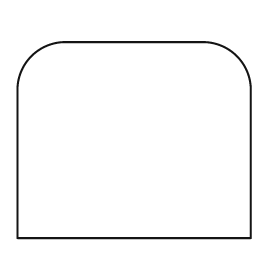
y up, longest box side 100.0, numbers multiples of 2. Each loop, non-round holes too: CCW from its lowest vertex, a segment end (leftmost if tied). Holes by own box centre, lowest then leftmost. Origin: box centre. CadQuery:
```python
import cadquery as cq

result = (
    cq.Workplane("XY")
    .moveTo(-50.0, -42.0)
    .lineTo(50.0, -42.0)
    .lineTo(50.0, 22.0)
    .threePointArc((44.0, 36.0), (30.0, 42.0))
    .lineTo(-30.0, 42.0)
    .threePointArc((-44.0, 36.0), (-50.0, 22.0))
    .close()
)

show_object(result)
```